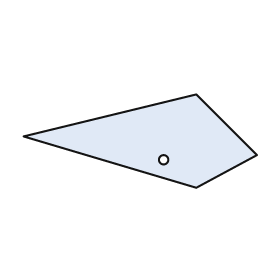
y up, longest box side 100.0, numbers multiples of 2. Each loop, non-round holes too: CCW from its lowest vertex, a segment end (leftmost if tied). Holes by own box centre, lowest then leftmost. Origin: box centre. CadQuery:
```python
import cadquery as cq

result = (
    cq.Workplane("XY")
    .moveTo(24.0, -20.0)
    .lineTo(50.0, -6.0)
    .lineTo(24.0, 20.0)
    .lineTo(-50.0, 2.0)
    .close()
    .moveTo(10.0, -8.0)
    .circle(2.0)
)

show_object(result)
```